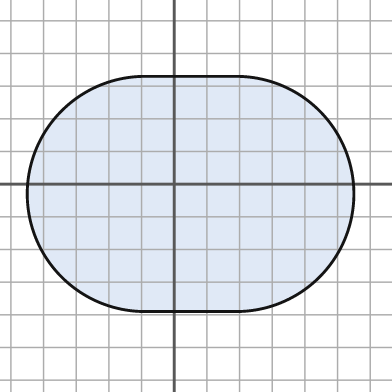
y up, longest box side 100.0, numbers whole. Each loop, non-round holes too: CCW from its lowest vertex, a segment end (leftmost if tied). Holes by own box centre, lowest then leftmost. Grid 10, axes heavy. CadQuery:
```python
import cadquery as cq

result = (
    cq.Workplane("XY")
    .moveTo(-9.0, -39.0)
    .lineTo(19.0, -39.0)
    .threePointArc((55.0, -3.0), (19.0, 33.0))
    .lineTo(-9.0, 33.0)
    .threePointArc((-45.0, -3.0), (-9.0, -39.0))
    .close()
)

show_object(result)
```